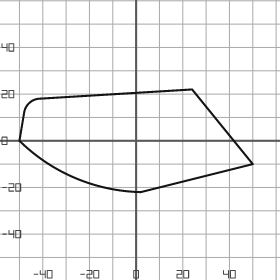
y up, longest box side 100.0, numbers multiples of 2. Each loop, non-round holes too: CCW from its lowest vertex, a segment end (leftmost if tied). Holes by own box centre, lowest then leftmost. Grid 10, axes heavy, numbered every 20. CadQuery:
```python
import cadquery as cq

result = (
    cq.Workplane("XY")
    .moveTo(2.0, -22.0)
    .lineTo(50.0, -10.0)
    .lineTo(24.0, 22.0)
    .lineTo(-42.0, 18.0)
    .threePointArc((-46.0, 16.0), (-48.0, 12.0))
    .lineTo(-50.0, 0.0)
    .threePointArc((-26.0, -16.0), (2.0, -22.0))
    .close()
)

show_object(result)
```